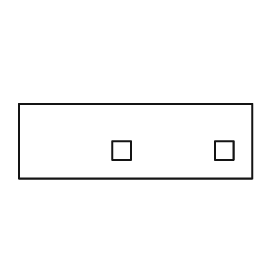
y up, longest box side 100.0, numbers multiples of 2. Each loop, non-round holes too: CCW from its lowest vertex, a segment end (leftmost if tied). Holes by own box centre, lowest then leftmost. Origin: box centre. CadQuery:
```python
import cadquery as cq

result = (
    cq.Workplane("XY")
    .moveTo(-50.0, -16.0)
    .lineTo(50.0, -16.0)
    .lineTo(50.0, 16.0)
    .lineTo(-50.0, 16.0)
    .close()
    .moveTo(-10.0, -8.0)
    .lineTo(-2.0, -8.0)
    .lineTo(-2.0, 0.0)
    .lineTo(-10.0, 0.0)
    .close()
    .moveTo(34.0, -8.0)
    .lineTo(42.0, -8.0)
    .lineTo(42.0, 0.0)
    .lineTo(34.0, 0.0)
    .close()
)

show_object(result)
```